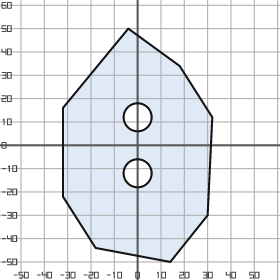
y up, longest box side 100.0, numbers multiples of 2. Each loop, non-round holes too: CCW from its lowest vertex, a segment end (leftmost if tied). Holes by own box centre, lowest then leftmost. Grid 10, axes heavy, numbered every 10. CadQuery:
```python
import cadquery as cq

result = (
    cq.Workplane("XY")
    .moveTo(14.0, -50.0)
    .lineTo(30.0, -30.0)
    .lineTo(32.0, 12.0)
    .lineTo(18.0, 34.0)
    .lineTo(-4.0, 50.0)
    .lineTo(-32.0, 16.0)
    .lineTo(-32.0, -22.0)
    .lineTo(-18.0, -44.0)
    .close()
    .moveTo(0.0, -12.0)
    .circle(6.0)
    .moveTo(0.0, 12.0)
    .circle(6.0)
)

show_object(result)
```